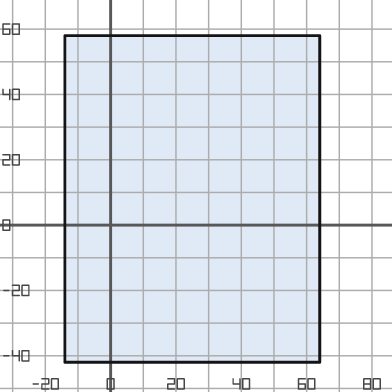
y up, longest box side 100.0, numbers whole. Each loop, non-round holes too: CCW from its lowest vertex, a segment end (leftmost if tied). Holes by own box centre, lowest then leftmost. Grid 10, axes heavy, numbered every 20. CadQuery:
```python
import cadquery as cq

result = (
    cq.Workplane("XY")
    .moveTo(-14.0, -42.0)
    .lineTo(64.0, -42.0)
    .lineTo(64.0, 58.0)
    .lineTo(-14.0, 58.0)
    .close()
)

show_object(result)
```